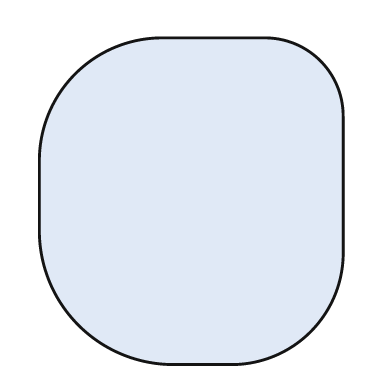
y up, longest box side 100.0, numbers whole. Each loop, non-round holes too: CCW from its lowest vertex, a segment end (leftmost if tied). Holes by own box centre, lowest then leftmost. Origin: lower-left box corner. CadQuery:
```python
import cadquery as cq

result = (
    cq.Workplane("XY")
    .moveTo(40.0, 0.0)
    .lineTo(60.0, 0.0)
    .threePointArc((83.0, 10.0), (93.0, 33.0))
    .lineTo(93.0, 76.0)
    .threePointArc((86.0, 93.0), (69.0, 100.0))
    .lineTo(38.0, 100.0)
    .threePointArc((11.0, 89.0), (0.0, 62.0))
    .lineTo(0.0, 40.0)
    .threePointArc((12.0, 12.0), (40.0, 0.0))
    .close()
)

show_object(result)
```